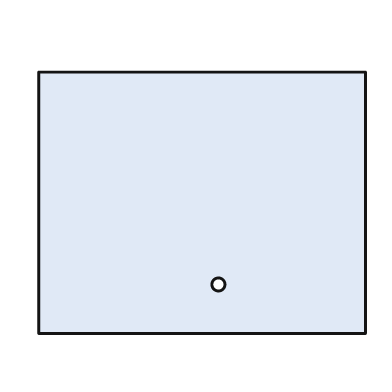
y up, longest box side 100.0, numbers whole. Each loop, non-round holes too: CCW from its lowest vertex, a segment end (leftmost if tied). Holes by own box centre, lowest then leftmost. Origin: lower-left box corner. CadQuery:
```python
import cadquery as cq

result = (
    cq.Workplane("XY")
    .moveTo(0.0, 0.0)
    .lineTo(100.0, 0.0)
    .lineTo(100.0, 80.0)
    .lineTo(0.0, 80.0)
    .close()
    .moveTo(55.0, 15.0)
    .circle(2.0)
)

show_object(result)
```